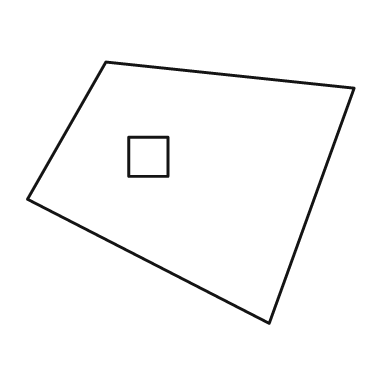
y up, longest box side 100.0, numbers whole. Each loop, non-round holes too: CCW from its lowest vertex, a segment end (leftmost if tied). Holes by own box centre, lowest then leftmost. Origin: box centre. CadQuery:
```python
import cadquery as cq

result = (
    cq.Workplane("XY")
    .moveTo(24.0, -40.0)
    .lineTo(50.0, 32.0)
    .lineTo(-26.0, 40.0)
    .lineTo(-50.0, -2.0)
    .close()
    .moveTo(-19.0, 5.0)
    .lineTo(-7.0, 5.0)
    .lineTo(-7.0, 17.0)
    .lineTo(-19.0, 17.0)
    .close()
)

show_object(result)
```